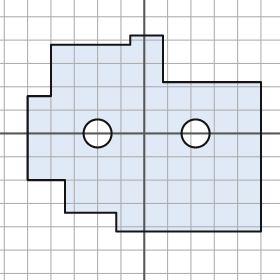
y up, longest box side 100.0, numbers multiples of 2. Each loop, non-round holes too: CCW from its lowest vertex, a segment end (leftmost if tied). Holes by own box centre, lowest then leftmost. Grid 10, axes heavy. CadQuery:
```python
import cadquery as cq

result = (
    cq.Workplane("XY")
    .moveTo(-12.0, -42.0)
    .lineTo(50.0, -42.0)
    .lineTo(50.0, 22.0)
    .lineTo(8.0, 22.0)
    .lineTo(8.0, 42.0)
    .lineTo(-6.0, 42.0)
    .lineTo(-6.0, 38.0)
    .lineTo(-40.0, 38.0)
    .lineTo(-40.0, 16.0)
    .lineTo(-50.0, 16.0)
    .lineTo(-50.0, -20.0)
    .lineTo(-34.0, -20.0)
    .lineTo(-34.0, -34.0)
    .lineTo(-12.0, -34.0)
    .close()
    .moveTo(-20.0, 0.0)
    .circle(6.0)
    .moveTo(22.0, 0.0)
    .circle(6.0)
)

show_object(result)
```